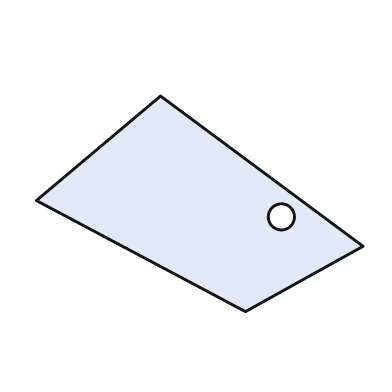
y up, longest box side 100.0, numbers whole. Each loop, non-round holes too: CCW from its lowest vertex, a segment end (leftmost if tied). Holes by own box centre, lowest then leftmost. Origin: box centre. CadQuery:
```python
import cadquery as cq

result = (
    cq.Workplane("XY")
    .moveTo(14.0, -33.0)
    .lineTo(50.0, -13.0)
    .lineTo(-12.0, 33.0)
    .lineTo(-50.0, 1.0)
    .close()
    .moveTo(25.0, -4.0)
    .circle(4.0)
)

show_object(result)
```